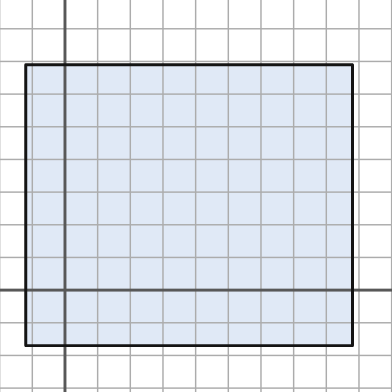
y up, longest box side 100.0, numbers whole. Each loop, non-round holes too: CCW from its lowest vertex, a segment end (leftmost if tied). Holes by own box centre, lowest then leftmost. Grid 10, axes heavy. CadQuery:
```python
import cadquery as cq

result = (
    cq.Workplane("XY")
    .moveTo(-12.0, -17.0)
    .lineTo(88.0, -17.0)
    .lineTo(88.0, 69.0)
    .lineTo(-12.0, 69.0)
    .close()
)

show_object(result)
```